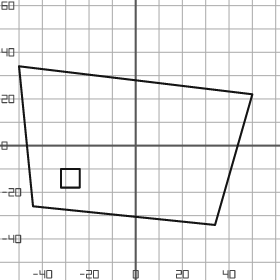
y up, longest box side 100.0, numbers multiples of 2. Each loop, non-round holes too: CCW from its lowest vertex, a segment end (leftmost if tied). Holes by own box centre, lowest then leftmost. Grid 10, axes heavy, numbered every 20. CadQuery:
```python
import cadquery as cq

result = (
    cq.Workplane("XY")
    .moveTo(34.0, -34.0)
    .lineTo(50.0, 22.0)
    .lineTo(-50.0, 34.0)
    .lineTo(-44.0, -26.0)
    .close()
    .moveTo(-32.0, -18.0)
    .lineTo(-24.0, -18.0)
    .lineTo(-24.0, -10.0)
    .lineTo(-32.0, -10.0)
    .close()
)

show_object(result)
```